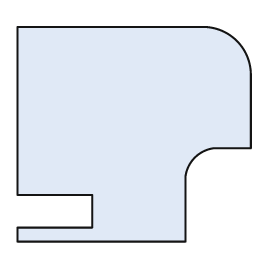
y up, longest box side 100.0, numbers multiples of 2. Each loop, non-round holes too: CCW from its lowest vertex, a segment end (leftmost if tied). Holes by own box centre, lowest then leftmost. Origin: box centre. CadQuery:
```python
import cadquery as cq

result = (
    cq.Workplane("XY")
    .moveTo(-50.0, -46.0)
    .lineTo(22.0, -46.0)
    .lineTo(22.0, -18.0)
    .threePointArc((26.0, -10.0), (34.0, -6.0))
    .lineTo(50.0, -6.0)
    .lineTo(50.0, 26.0)
    .threePointArc((44.0, 40.0), (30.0, 46.0))
    .lineTo(-50.0, 46.0)
    .lineTo(-50.0, -26.0)
    .lineTo(-18.0, -26.0)
    .lineTo(-18.0, -40.0)
    .lineTo(-50.0, -40.0)
    .close()
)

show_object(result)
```